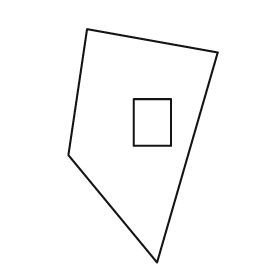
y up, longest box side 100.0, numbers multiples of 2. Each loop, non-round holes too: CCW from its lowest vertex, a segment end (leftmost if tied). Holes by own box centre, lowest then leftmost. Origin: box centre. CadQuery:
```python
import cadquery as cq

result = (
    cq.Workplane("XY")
    .moveTo(6.0, -50.0)
    .lineTo(32.0, 40.0)
    .lineTo(-24.0, 50.0)
    .lineTo(-32.0, -4.0)
    .close()
    .moveTo(-4.0, 0.0)
    .lineTo(12.0, 0.0)
    .lineTo(12.0, 20.0)
    .lineTo(-4.0, 20.0)
    .close()
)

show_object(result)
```